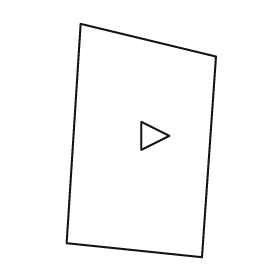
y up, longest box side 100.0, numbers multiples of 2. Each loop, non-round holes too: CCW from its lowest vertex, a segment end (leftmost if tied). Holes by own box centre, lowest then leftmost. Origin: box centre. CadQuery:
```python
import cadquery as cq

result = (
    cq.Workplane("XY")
    .moveTo(26.0, -50.0)
    .lineTo(32.0, 36.0)
    .lineTo(-26.0, 50.0)
    .lineTo(-32.0, -44.0)
    .close()
    .moveTo(0.0, -4.0)
    .lineTo(12.0, 2.0)
    .lineTo(0.0, 8.0)
    .close()
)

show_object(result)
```